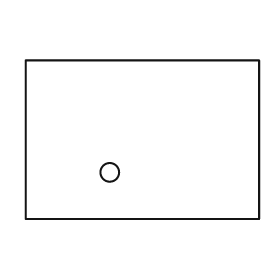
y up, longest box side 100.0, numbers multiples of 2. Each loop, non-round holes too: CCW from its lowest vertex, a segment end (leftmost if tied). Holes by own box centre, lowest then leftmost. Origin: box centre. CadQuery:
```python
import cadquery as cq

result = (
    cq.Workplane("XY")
    .moveTo(-50.0, -34.0)
    .lineTo(50.0, -34.0)
    .lineTo(50.0, 34.0)
    .lineTo(-50.0, 34.0)
    .close()
    .moveTo(-14.0, -14.0)
    .circle(4.0)
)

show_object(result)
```